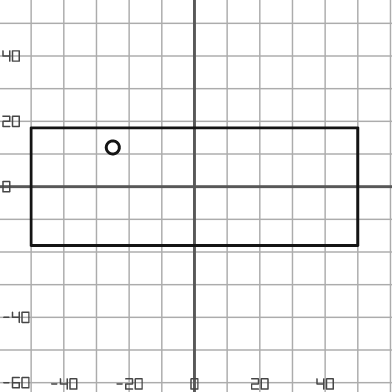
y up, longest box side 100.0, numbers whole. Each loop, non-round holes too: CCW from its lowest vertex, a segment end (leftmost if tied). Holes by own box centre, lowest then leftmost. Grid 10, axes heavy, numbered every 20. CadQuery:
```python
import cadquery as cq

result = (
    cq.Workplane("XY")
    .moveTo(-50.0, -18.0)
    .lineTo(50.0, -18.0)
    .lineTo(50.0, 18.0)
    .lineTo(-50.0, 18.0)
    .close()
    .moveTo(-25.0, 12.0)
    .circle(2.0)
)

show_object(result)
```